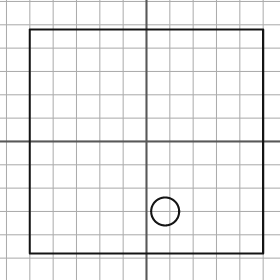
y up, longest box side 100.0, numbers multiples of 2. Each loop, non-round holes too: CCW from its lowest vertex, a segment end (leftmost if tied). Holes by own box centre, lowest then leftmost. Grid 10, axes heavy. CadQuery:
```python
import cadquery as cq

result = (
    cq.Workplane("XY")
    .moveTo(-50.0, -48.0)
    .lineTo(50.0, -48.0)
    .lineTo(50.0, 48.0)
    .lineTo(-50.0, 48.0)
    .close()
    .moveTo(8.0, -30.0)
    .circle(6.0)
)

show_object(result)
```